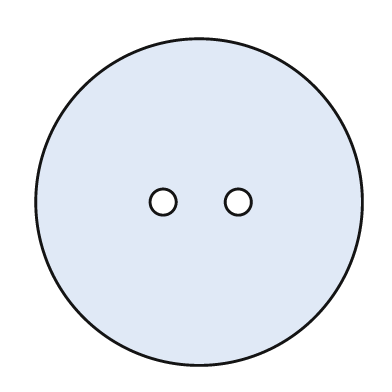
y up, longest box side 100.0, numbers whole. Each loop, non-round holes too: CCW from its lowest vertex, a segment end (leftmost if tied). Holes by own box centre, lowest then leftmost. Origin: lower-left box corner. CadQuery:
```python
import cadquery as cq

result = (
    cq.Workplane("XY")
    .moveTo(50.0, 50.0)
    .circle(50.0)
    .moveTo(39.0, 50.0)
    .circle(4.0)
    .moveTo(62.0, 50.0)
    .circle(4.0)
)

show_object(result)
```